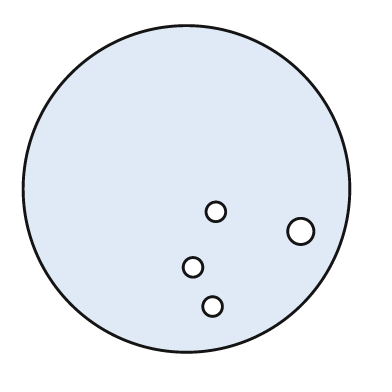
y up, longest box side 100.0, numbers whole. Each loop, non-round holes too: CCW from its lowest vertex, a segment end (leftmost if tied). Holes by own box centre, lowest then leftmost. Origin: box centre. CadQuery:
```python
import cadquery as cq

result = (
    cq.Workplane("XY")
    .moveTo(0.0, 0.0)
    .circle(50.0)
    .moveTo(8.0, -36.0)
    .circle(3.0)
    .moveTo(2.0, -24.0)
    .circle(3.0)
    .moveTo(35.0, -13.0)
    .circle(4.0)
    .moveTo(9.0, -7.0)
    .circle(3.0)
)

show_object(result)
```